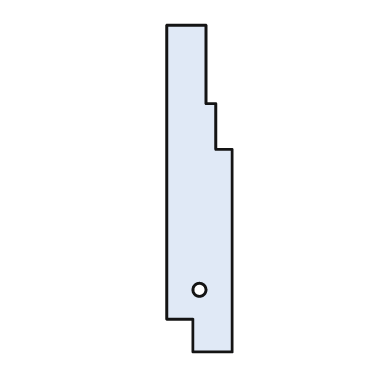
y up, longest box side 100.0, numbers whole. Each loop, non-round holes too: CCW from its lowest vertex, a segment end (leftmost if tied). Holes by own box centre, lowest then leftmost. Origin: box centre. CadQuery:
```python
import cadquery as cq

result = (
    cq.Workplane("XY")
    .moveTo(-2.0, -50.0)
    .lineTo(10.0, -50.0)
    .lineTo(10.0, 12.0)
    .lineTo(5.0, 12.0)
    .lineTo(5.0, 26.0)
    .lineTo(2.0, 26.0)
    .lineTo(2.0, 50.0)
    .lineTo(-10.0, 50.0)
    .lineTo(-10.0, -40.0)
    .lineTo(-2.0, -40.0)
    .close()
    .moveTo(0.0, -31.0)
    .circle(2.0)
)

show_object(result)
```